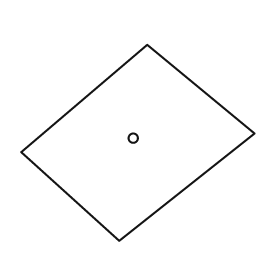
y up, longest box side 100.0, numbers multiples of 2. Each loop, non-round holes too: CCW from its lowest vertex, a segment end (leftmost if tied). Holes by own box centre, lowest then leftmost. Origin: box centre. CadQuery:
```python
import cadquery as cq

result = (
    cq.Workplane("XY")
    .moveTo(-8.0, -42.0)
    .lineTo(50.0, 4.0)
    .lineTo(4.0, 42.0)
    .lineTo(-50.0, -4.0)
    .close()
    .moveTo(-2.0, 2.0)
    .circle(2.0)
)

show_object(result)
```